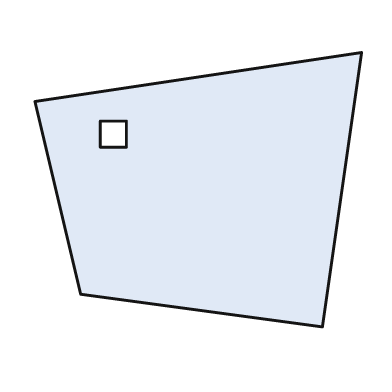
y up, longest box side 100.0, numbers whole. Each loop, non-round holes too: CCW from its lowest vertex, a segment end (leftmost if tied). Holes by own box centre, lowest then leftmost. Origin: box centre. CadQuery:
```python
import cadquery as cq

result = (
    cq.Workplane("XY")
    .moveTo(38.0, -42.0)
    .lineTo(50.0, 42.0)
    .lineTo(-50.0, 27.0)
    .lineTo(-36.0, -32.0)
    .close()
    .moveTo(-30.0, 13.0)
    .lineTo(-22.0, 13.0)
    .lineTo(-22.0, 21.0)
    .lineTo(-30.0, 21.0)
    .close()
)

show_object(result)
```